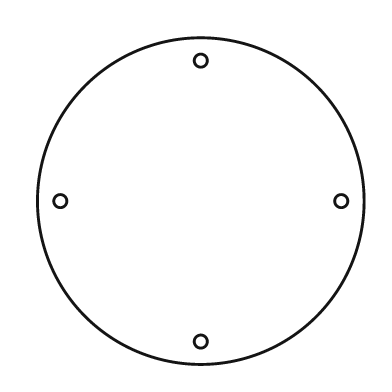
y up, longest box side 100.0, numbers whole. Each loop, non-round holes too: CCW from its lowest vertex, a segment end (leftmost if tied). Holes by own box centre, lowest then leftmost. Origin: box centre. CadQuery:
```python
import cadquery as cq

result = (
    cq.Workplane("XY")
    .moveTo(0.0, 0.0)
    .circle(50.0)
    .moveTo(0.0, -43.0)
    .circle(2.0)
    .moveTo(-43.0, 0.0)
    .circle(2.0)
    .moveTo(43.0, 0.0)
    .circle(2.0)
    .moveTo(0.0, 43.0)
    .circle(2.0)
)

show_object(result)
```